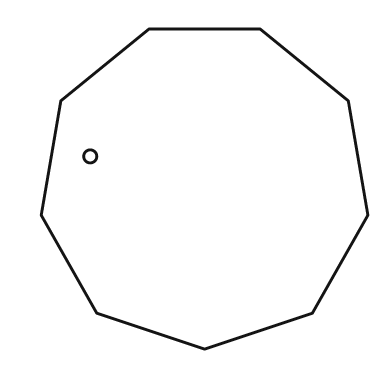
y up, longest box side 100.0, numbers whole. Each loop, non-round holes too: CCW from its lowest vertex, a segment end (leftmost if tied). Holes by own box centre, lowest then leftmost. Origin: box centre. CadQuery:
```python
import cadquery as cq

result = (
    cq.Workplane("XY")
    .moveTo(0.0, -49.0)
    .lineTo(33.0, -38.0)
    .lineTo(50.0, -8.0)
    .lineTo(44.0, 27.0)
    .lineTo(17.0, 49.0)
    .lineTo(-17.0, 49.0)
    .lineTo(-44.0, 27.0)
    .lineTo(-50.0, -8.0)
    .lineTo(-33.0, -38.0)
    .close()
    .moveTo(-35.0, 10.0)
    .circle(2.0)
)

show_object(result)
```